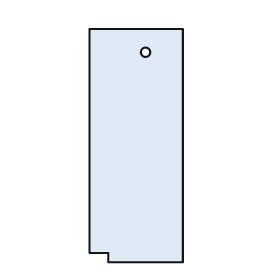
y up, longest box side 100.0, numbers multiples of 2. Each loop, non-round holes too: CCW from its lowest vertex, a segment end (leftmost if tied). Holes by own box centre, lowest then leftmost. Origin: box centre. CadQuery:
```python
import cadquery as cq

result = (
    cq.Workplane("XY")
    .moveTo(-12.0, -50.0)
    .lineTo(20.0, -50.0)
    .lineTo(20.0, 50.0)
    .lineTo(-20.0, 50.0)
    .lineTo(-20.0, -46.0)
    .lineTo(-12.0, -46.0)
    .close()
    .moveTo(4.0, 40.0)
    .circle(2.0)
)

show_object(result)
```